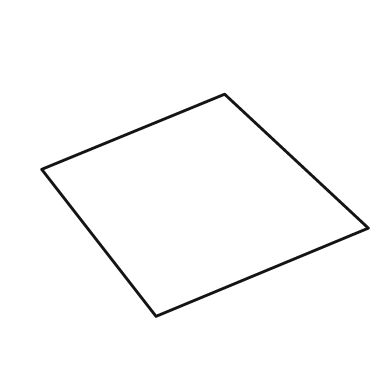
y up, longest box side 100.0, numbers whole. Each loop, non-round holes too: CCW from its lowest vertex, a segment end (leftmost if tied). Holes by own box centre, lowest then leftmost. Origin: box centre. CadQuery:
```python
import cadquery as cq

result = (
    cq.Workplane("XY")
    .moveTo(-15.0, -34.0)
    .lineTo(50.0, -7.0)
    .lineTo(6.0, 34.0)
    .lineTo(-50.0, 11.0)
    .close()
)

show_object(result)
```